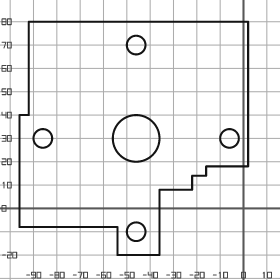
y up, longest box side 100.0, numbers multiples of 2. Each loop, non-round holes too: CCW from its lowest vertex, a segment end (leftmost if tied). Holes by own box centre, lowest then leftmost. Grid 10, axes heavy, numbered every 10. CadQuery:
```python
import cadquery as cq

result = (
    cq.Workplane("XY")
    .moveTo(-54.0, -20.0)
    .lineTo(-36.0, -20.0)
    .lineTo(-36.0, 8.0)
    .lineTo(-22.0, 8.0)
    .lineTo(-22.0, 14.0)
    .lineTo(-16.0, 14.0)
    .lineTo(-16.0, 18.0)
    .lineTo(2.0, 18.0)
    .lineTo(2.0, 80.0)
    .lineTo(-92.0, 80.0)
    .lineTo(-92.0, 40.0)
    .lineTo(-96.0, 40.0)
    .lineTo(-96.0, -8.0)
    .lineTo(-54.0, -8.0)
    .close()
    .moveTo(-46.0, -10.0)
    .circle(4.0)
    .moveTo(-86.0, 30.0)
    .circle(4.0)
    .moveTo(-46.0, 30.0)
    .circle(10.0)
    .moveTo(-6.0, 30.0)
    .circle(4.0)
    .moveTo(-46.0, 70.0)
    .circle(4.0)
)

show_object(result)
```